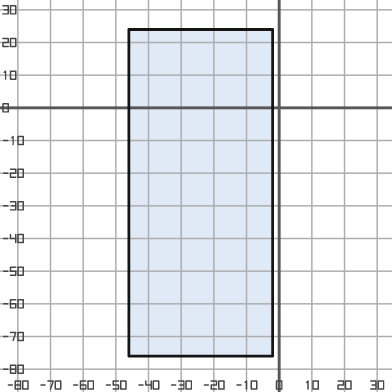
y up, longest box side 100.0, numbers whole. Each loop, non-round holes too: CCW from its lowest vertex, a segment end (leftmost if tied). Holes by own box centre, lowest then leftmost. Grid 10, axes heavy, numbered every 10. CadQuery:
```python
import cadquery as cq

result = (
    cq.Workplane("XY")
    .moveTo(-46.0, -76.0)
    .lineTo(-2.0, -76.0)
    .lineTo(-2.0, 24.0)
    .lineTo(-46.0, 24.0)
    .close()
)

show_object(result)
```